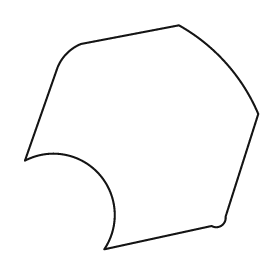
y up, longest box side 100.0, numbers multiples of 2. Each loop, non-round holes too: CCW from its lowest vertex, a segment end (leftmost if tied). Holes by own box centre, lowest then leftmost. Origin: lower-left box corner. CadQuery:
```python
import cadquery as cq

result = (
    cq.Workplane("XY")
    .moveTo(34.0, 0.0)
    .lineTo(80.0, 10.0)
    .threePointArc((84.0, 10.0), (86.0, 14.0))
    .lineTo(100.0, 58.0)
    .threePointArc((86.0, 80.0), (66.0, 96.0))
    .lineTo(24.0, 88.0)
    .threePointArc((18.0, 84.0), (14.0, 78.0))
    .lineTo(0.0, 38.0)
    .threePointArc((32.0, 32.0), (34.0, 0.0))
    .close()
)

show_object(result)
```